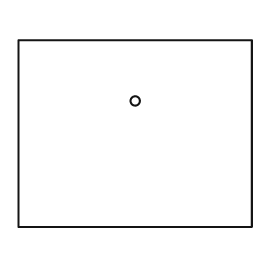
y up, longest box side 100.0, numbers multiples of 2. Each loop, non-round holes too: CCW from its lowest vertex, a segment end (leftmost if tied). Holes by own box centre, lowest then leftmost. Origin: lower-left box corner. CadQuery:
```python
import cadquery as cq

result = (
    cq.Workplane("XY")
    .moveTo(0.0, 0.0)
    .lineTo(100.0, 0.0)
    .lineTo(100.0, 80.0)
    .lineTo(0.0, 80.0)
    .close()
    .moveTo(50.0, 54.0)
    .circle(2.0)
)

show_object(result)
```